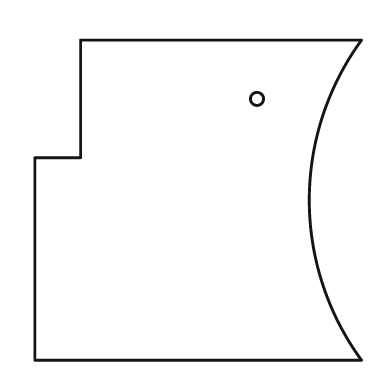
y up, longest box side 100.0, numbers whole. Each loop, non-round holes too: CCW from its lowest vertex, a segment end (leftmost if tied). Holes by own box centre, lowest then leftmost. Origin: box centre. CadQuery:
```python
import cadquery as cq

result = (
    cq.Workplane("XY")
    .moveTo(-50.0, -49.0)
    .lineTo(50.0, -49.0)
    .threePointArc((34.0, 0.0), (50.0, 49.0))
    .lineTo(-36.0, 49.0)
    .lineTo(-36.0, 13.0)
    .lineTo(-50.0, 13.0)
    .close()
    .moveTo(18.0, 31.0)
    .circle(2.0)
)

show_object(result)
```